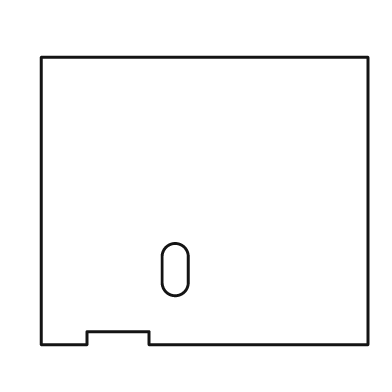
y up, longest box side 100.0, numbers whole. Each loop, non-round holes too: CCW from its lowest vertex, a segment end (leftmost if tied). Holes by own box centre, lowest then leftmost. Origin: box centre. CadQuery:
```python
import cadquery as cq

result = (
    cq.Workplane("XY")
    .moveTo(-50.0, -44.0)
    .lineTo(-36.0, -44.0)
    .lineTo(-36.0, -40.0)
    .lineTo(-17.0, -40.0)
    .lineTo(-17.0, -44.0)
    .lineTo(50.0, -44.0)
    .lineTo(50.0, 44.0)
    .lineTo(-50.0, 44.0)
    .close()
    .moveTo(-13.0, -25.0)
    .threePointArc((-9.0, -29.0), (-5.0, -25.0))
    .lineTo(-5.0, -17.0)
    .threePointArc((-9.0, -13.0), (-13.0, -17.0))
    .close()
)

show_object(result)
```